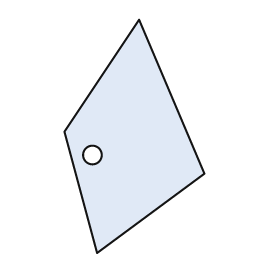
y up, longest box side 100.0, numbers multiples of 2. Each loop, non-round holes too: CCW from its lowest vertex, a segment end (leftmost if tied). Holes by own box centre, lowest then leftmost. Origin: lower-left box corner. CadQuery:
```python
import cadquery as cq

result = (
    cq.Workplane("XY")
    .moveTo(14.0, 0.0)
    .lineTo(60.0, 34.0)
    .lineTo(32.0, 100.0)
    .lineTo(0.0, 52.0)
    .close()
    .moveTo(12.0, 42.0)
    .circle(4.0)
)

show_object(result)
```